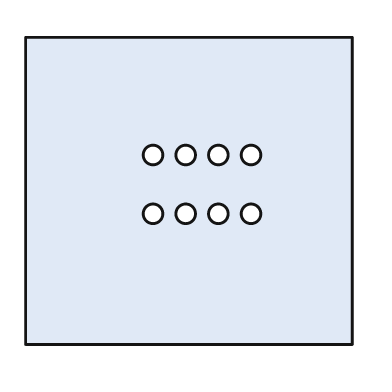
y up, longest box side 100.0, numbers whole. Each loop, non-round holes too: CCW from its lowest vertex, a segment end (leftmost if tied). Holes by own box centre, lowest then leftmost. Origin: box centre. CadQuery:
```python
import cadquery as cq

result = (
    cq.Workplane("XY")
    .moveTo(-50.0, -47.0)
    .lineTo(50.0, -47.0)
    .lineTo(50.0, 47.0)
    .lineTo(-50.0, 47.0)
    .close()
    .moveTo(-11.0, -7.0)
    .circle(3.0)
    .moveTo(-1.0, -7.0)
    .circle(3.0)
    .moveTo(9.0, -7.0)
    .circle(3.0)
    .moveTo(19.0, -7.0)
    .circle(3.0)
    .moveTo(-11.0, 11.0)
    .circle(3.0)
    .moveTo(-1.0, 11.0)
    .circle(3.0)
    .moveTo(9.0, 11.0)
    .circle(3.0)
    .moveTo(19.0, 11.0)
    .circle(3.0)
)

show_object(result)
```